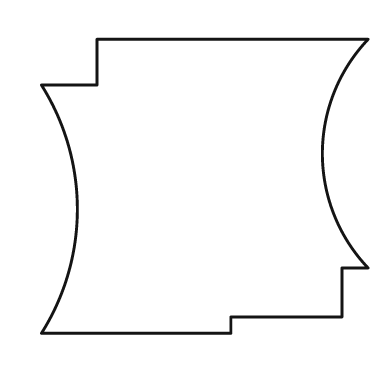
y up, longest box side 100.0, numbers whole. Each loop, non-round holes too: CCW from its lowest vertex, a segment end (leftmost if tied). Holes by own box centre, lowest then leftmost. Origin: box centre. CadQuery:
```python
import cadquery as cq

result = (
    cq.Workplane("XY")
    .moveTo(-50.0, -45.0)
    .lineTo(8.0, -45.0)
    .lineTo(8.0, -40.0)
    .lineTo(42.0, -40.0)
    .lineTo(42.0, -25.0)
    .lineTo(50.0, -25.0)
    .threePointArc((36.0, 10.0), (50.0, 45.0))
    .lineTo(-33.0, 45.0)
    .lineTo(-33.0, 31.0)
    .lineTo(-50.0, 31.0)
    .threePointArc((-39.0, -7.0), (-50.0, -45.0))
    .close()
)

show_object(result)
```